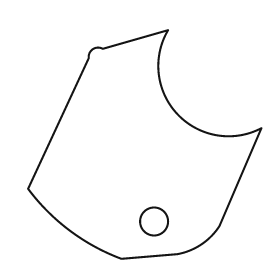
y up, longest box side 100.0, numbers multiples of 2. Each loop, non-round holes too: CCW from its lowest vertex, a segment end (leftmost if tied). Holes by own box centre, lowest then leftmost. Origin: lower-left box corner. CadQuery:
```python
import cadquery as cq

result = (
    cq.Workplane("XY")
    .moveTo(40.0, 0.0)
    .lineTo(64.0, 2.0)
    .threePointArc((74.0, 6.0), (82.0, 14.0))
    .lineTo(100.0, 56.0)
    .threePointArc((64.0, 62.0), (60.0, 98.0))
    .lineTo(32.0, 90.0)
    .threePointArc((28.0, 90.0), (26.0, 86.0))
    .lineTo(0.0, 30.0)
    .threePointArc((18.0, 12.0), (40.0, 0.0))
    .close()
    .moveTo(54.0, 16.0)
    .circle(6.0)
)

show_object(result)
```